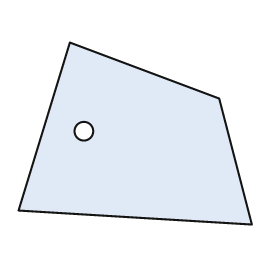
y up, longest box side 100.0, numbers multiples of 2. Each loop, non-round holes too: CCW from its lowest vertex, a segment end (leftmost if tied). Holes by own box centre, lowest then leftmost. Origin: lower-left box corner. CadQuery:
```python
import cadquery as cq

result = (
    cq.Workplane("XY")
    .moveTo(100.0, 0.0)
    .lineTo(86.0, 54.0)
    .lineTo(22.0, 78.0)
    .lineTo(0.0, 6.0)
    .close()
    .moveTo(28.0, 40.0)
    .circle(4.0)
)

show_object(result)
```